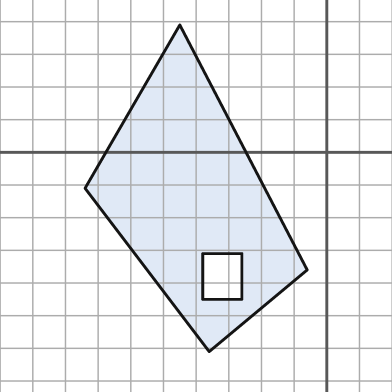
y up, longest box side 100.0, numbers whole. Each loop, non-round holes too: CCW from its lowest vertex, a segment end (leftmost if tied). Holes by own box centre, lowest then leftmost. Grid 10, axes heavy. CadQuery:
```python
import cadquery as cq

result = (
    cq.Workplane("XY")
    .moveTo(-36.0, -61.0)
    .lineTo(-6.0, -36.0)
    .lineTo(-45.0, 39.0)
    .lineTo(-74.0, -11.0)
    .close()
    .moveTo(-38.0, -45.0)
    .lineTo(-26.0, -45.0)
    .lineTo(-26.0, -31.0)
    .lineTo(-38.0, -31.0)
    .close()
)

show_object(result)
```